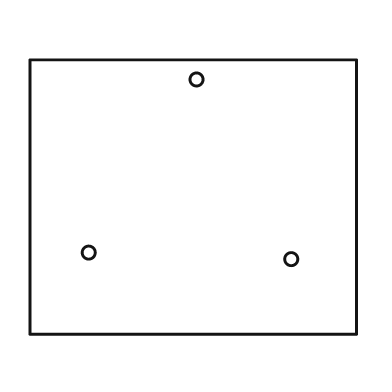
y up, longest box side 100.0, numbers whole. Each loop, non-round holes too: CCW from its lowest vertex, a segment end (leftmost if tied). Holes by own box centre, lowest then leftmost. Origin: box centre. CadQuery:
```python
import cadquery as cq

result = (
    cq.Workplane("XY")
    .moveTo(-50.0, -42.0)
    .lineTo(50.0, -42.0)
    .lineTo(50.0, 42.0)
    .lineTo(-50.0, 42.0)
    .close()
    .moveTo(30.0, -19.0)
    .circle(2.0)
    .moveTo(-32.0, -17.0)
    .circle(2.0)
    .moveTo(1.0, 36.0)
    .circle(2.0)
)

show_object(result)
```